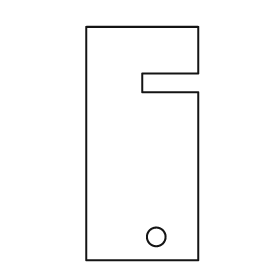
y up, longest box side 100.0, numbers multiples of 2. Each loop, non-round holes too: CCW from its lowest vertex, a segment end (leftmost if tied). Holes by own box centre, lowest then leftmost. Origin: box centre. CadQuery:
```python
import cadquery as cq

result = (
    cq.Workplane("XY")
    .moveTo(-24.0, -50.0)
    .lineTo(24.0, -50.0)
    .lineTo(24.0, 22.0)
    .lineTo(0.0, 22.0)
    .lineTo(0.0, 30.0)
    .lineTo(24.0, 30.0)
    .lineTo(24.0, 50.0)
    .lineTo(-24.0, 50.0)
    .close()
    .moveTo(6.0, -40.0)
    .circle(4.0)
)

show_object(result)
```